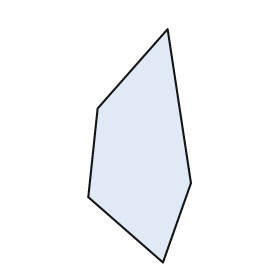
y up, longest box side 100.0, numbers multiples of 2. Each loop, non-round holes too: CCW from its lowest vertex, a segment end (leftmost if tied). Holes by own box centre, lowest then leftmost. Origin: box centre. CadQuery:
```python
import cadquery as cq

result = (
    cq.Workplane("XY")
    .moveTo(10.0, -50.0)
    .lineTo(22.0, -16.0)
    .lineTo(12.0, 50.0)
    .lineTo(-18.0, 16.0)
    .lineTo(-22.0, -22.0)
    .close()
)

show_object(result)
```